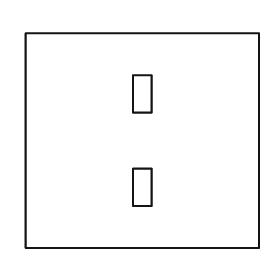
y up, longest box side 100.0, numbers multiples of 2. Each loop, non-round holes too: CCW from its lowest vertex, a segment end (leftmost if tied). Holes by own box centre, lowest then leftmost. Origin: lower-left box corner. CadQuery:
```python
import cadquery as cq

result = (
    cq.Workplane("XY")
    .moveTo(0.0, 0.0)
    .lineTo(100.0, 0.0)
    .lineTo(100.0, 92.0)
    .lineTo(0.0, 92.0)
    .close()
    .moveTo(46.0, 18.0)
    .lineTo(54.0, 18.0)
    .lineTo(54.0, 34.0)
    .lineTo(46.0, 34.0)
    .close()
    .moveTo(46.0, 58.0)
    .lineTo(54.0, 58.0)
    .lineTo(54.0, 74.0)
    .lineTo(46.0, 74.0)
    .close()
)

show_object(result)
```